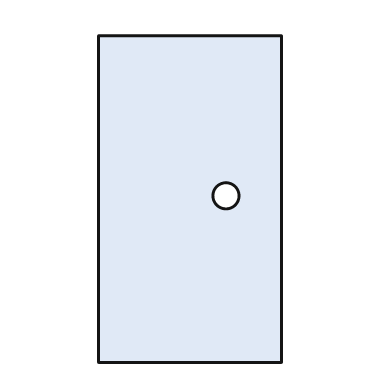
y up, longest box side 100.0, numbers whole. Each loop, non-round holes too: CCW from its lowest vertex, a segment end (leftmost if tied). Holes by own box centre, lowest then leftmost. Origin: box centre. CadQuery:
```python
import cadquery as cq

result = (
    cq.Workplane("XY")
    .moveTo(-28.0, -50.0)
    .lineTo(28.0, -50.0)
    .lineTo(28.0, 50.0)
    .lineTo(-28.0, 50.0)
    .close()
    .moveTo(11.0, 1.0)
    .circle(4.0)
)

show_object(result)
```